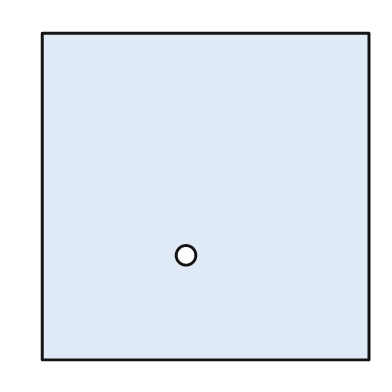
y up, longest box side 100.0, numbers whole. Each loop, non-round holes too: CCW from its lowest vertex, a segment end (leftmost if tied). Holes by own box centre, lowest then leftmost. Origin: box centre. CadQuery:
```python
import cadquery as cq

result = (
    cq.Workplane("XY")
    .moveTo(-50.0, -50.0)
    .lineTo(50.0, -50.0)
    .lineTo(50.0, 50.0)
    .lineTo(-50.0, 50.0)
    .close()
    .moveTo(-6.0, -18.0)
    .circle(3.0)
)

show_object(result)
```